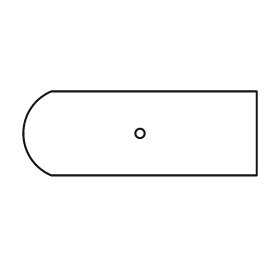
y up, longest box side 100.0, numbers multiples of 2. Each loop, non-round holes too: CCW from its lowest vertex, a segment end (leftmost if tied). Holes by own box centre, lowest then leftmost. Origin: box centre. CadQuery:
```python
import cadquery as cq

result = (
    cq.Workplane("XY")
    .moveTo(-38.0, -18.0)
    .lineTo(50.0, -18.0)
    .lineTo(50.0, 18.0)
    .lineTo(-38.0, 18.0)
    .threePointArc((-50.0, 0.0), (-38.0, -18.0))
    .close()
    .moveTo(0.0, 0.0)
    .circle(2.0)
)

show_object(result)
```